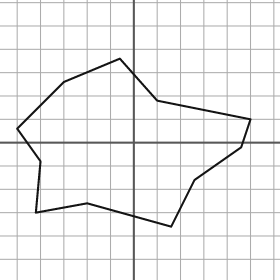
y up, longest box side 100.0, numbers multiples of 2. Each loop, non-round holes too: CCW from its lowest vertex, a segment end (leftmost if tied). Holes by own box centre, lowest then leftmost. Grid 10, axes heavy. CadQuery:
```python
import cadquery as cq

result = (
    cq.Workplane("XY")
    .moveTo(16.0, -36.0)
    .lineTo(26.0, -16.0)
    .lineTo(46.0, -2.0)
    .lineTo(50.0, 10.0)
    .lineTo(10.0, 18.0)
    .lineTo(-6.0, 36.0)
    .lineTo(-30.0, 26.0)
    .lineTo(-50.0, 6.0)
    .lineTo(-40.0, -8.0)
    .lineTo(-42.0, -30.0)
    .lineTo(-20.0, -26.0)
    .close()
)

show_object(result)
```